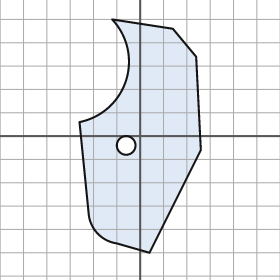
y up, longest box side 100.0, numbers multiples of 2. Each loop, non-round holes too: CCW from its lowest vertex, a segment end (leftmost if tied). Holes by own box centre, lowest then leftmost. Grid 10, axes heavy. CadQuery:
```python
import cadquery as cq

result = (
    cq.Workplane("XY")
    .moveTo(4.0, -50.0)
    .lineTo(26.0, -6.0)
    .lineTo(24.0, 34.0)
    .lineTo(14.0, 46.0)
    .lineTo(-12.0, 50.0)
    .threePointArc((-6.0, 24.0), (-26.0, 6.0))
    .lineTo(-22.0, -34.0)
    .threePointArc((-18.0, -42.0), (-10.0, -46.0))
    .close()
    .moveTo(-6.0, -4.0)
    .circle(4.0)
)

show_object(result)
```